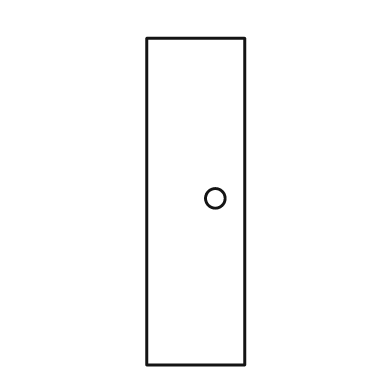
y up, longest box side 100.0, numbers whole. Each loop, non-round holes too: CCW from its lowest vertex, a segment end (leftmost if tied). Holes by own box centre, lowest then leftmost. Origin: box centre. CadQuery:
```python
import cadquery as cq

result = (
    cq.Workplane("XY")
    .moveTo(-15.0, -50.0)
    .lineTo(15.0, -50.0)
    .lineTo(15.0, 50.0)
    .lineTo(-15.0, 50.0)
    .close()
    .moveTo(6.0, 1.0)
    .circle(3.0)
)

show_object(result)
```